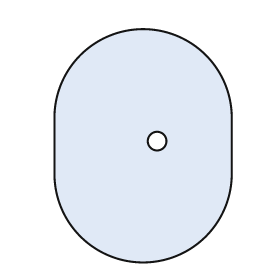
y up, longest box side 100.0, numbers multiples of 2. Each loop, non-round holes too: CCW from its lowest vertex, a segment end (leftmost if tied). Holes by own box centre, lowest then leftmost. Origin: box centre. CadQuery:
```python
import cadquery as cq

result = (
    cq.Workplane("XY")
    .moveTo(-38.0, -12.0)
    .threePointArc((0.0, -50.0), (38.0, -12.0))
    .lineTo(38.0, 12.0)
    .threePointArc((0.0, 50.0), (-38.0, 12.0))
    .close()
    .moveTo(6.0, 2.0)
    .circle(4.0)
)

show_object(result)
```